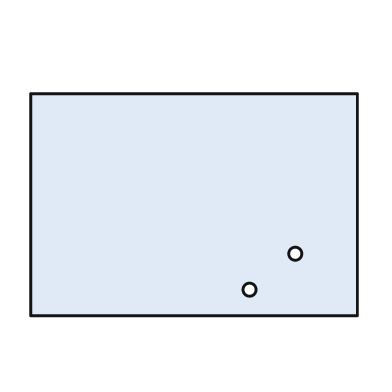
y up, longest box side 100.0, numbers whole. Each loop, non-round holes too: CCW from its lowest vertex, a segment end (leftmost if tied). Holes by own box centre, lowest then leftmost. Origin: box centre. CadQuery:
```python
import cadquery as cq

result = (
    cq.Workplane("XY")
    .moveTo(-50.0, -34.0)
    .lineTo(50.0, -34.0)
    .lineTo(50.0, 34.0)
    .lineTo(-50.0, 34.0)
    .close()
    .moveTo(17.0, -26.0)
    .circle(2.0)
    .moveTo(31.0, -15.0)
    .circle(2.0)
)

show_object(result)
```